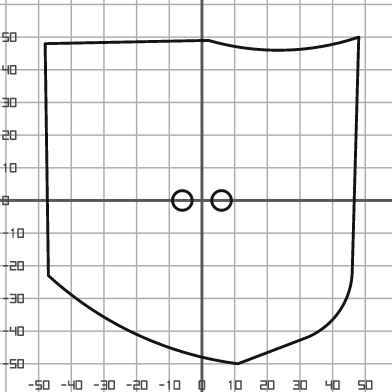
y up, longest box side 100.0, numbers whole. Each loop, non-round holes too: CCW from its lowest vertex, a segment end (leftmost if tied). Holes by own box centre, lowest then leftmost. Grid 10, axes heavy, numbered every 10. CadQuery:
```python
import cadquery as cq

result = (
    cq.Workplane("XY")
    .moveTo(11.0, -50.0)
    .lineTo(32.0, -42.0)
    .threePointArc((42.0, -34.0), (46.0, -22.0))
    .lineTo(48.0, 50.0)
    .threePointArc((25.0, 46.0), (2.0, 49.0))
    .lineTo(-48.0, 48.0)
    .lineTo(-47.0, -23.0)
    .threePointArc((-20.0, -41.0), (11.0, -50.0))
    .close()
    .moveTo(-6.0, 0.0)
    .circle(3.0)
    .moveTo(6.0, 0.0)
    .circle(3.0)
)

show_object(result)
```